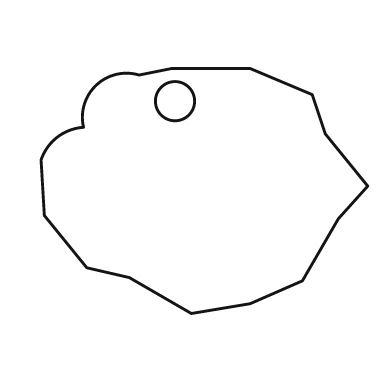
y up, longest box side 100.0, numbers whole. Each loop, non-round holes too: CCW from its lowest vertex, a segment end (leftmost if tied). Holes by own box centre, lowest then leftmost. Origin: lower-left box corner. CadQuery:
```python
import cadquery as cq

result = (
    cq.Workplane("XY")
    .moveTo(46.0, 0.0)
    .lineTo(64.0, 3.0)
    .lineTo(80.0, 10.0)
    .lineTo(91.0, 29.0)
    .lineTo(100.0, 39.0)
    .lineTo(87.0, 55.0)
    .lineTo(83.0, 67.0)
    .lineTo(64.0, 75.0)
    .lineTo(40.0, 75.0)
    .lineTo(30.0, 73.0)
    .threePointArc((17.0, 70.0), (13.0, 57.0))
    .threePointArc((5.0, 54.0), (0.0, 47.0))
    .lineTo(1.0, 30.0)
    .lineTo(14.0, 14.0)
    .lineTo(27.0, 11.0)
    .close()
    .moveTo(41.0, 65.0)
    .circle(6.0)
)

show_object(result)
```